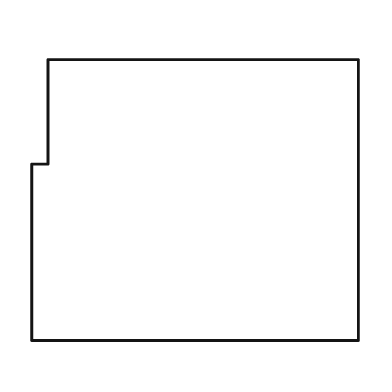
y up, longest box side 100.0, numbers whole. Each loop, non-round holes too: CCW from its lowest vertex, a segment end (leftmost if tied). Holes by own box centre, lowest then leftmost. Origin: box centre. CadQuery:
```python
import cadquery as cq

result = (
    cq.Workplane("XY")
    .moveTo(-50.0, -43.0)
    .lineTo(50.0, -43.0)
    .lineTo(50.0, 43.0)
    .lineTo(-45.0, 43.0)
    .lineTo(-45.0, 11.0)
    .lineTo(-50.0, 11.0)
    .close()
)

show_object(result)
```